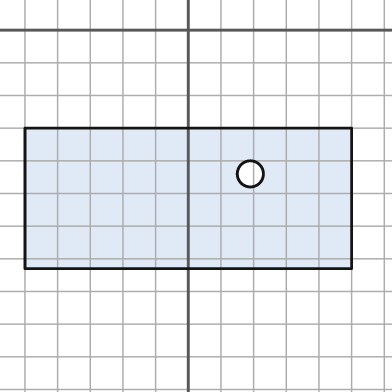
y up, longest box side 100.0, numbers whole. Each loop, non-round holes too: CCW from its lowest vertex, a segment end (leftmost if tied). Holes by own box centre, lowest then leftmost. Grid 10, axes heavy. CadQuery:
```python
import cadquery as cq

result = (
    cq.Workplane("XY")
    .moveTo(-50.0, -73.0)
    .lineTo(50.0, -73.0)
    .lineTo(50.0, -30.0)
    .lineTo(-50.0, -30.0)
    .close()
    .moveTo(19.0, -44.0)
    .circle(4.0)
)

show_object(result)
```